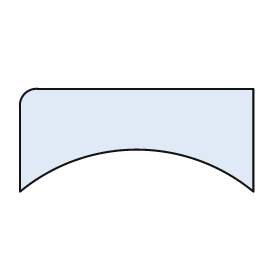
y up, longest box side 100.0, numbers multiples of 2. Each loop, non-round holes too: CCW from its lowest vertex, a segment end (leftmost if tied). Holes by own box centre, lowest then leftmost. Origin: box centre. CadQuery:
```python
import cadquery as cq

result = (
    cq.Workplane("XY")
    .moveTo(-50.0, -22.0)
    .threePointArc((0.0, -4.0), (50.0, -22.0))
    .lineTo(50.0, 22.0)
    .lineTo(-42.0, 22.0)
    .threePointArc((-48.0, 20.0), (-50.0, 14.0))
    .close()
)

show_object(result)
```